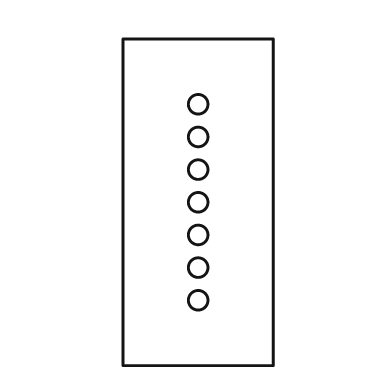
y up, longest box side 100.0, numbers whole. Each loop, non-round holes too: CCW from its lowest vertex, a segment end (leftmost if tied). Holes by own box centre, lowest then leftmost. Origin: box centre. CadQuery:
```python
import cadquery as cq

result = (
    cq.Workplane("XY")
    .moveTo(-23.0, -50.0)
    .lineTo(23.0, -50.0)
    .lineTo(23.0, 50.0)
    .lineTo(-23.0, 50.0)
    .close()
    .moveTo(0.0, -30.0)
    .circle(3.0)
    .moveTo(0.0, -20.0)
    .circle(3.0)
    .moveTo(0.0, -10.0)
    .circle(3.0)
    .moveTo(0.0, 0.0)
    .circle(3.0)
    .moveTo(0.0, 10.0)
    .circle(3.0)
    .moveTo(0.0, 20.0)
    .circle(3.0)
    .moveTo(0.0, 30.0)
    .circle(3.0)
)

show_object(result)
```